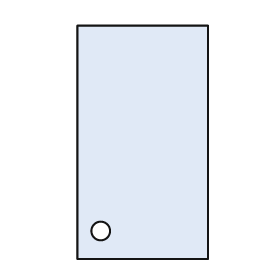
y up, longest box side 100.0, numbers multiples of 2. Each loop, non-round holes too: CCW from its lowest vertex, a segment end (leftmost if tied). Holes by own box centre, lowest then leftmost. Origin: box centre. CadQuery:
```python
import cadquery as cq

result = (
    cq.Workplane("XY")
    .moveTo(-28.0, -50.0)
    .lineTo(28.0, -50.0)
    .lineTo(28.0, 50.0)
    .lineTo(-28.0, 50.0)
    .close()
    .moveTo(-18.0, -38.0)
    .circle(4.0)
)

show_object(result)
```